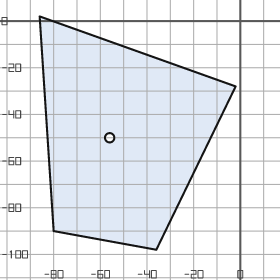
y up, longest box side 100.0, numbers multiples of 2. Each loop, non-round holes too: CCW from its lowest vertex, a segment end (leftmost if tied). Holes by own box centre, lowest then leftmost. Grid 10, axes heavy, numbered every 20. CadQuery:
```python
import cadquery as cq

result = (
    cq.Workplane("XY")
    .moveTo(-36.0, -98.0)
    .lineTo(-2.0, -28.0)
    .lineTo(-86.0, 2.0)
    .lineTo(-80.0, -90.0)
    .close()
    .moveTo(-56.0, -50.0)
    .circle(2.0)
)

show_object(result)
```